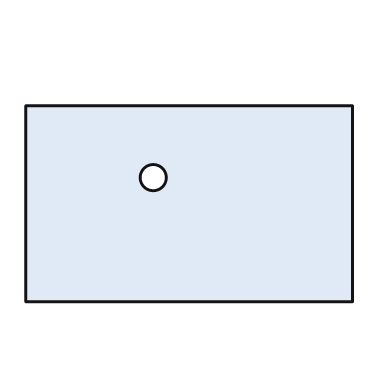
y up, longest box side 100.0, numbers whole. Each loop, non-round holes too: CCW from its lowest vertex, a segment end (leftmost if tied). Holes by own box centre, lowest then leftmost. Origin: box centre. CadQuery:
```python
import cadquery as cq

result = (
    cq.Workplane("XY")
    .moveTo(-50.0, -30.0)
    .lineTo(50.0, -30.0)
    .lineTo(50.0, 30.0)
    .lineTo(-50.0, 30.0)
    .close()
    .moveTo(-11.0, 8.0)
    .circle(4.0)
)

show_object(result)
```